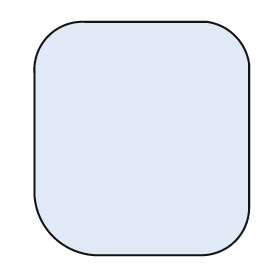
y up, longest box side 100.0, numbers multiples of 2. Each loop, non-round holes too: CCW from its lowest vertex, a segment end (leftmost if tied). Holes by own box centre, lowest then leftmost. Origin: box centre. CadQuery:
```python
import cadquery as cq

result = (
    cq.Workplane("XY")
    .moveTo(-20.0, -50.0)
    .lineTo(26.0, -50.0)
    .threePointArc((40.0, -44.0), (46.0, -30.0))
    .lineTo(46.0, 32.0)
    .threePointArc((40.0, 44.0), (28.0, 50.0))
    .lineTo(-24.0, 50.0)
    .threePointArc((-40.0, 44.0), (-46.0, 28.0))
    .lineTo(-46.0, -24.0)
    .threePointArc((-38.0, -42.0), (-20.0, -50.0))
    .close()
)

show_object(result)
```